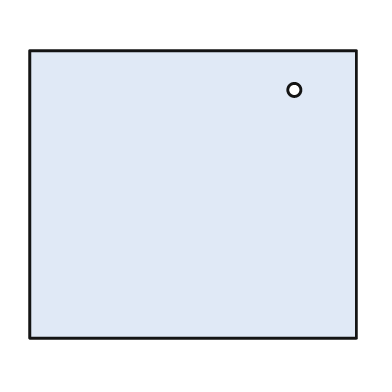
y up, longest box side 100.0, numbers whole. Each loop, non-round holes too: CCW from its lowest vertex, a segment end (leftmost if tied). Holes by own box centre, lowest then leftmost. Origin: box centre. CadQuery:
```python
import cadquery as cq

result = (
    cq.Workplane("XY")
    .moveTo(-50.0, -44.0)
    .lineTo(50.0, -44.0)
    .lineTo(50.0, 44.0)
    .lineTo(-50.0, 44.0)
    .close()
    .moveTo(31.0, 32.0)
    .circle(2.0)
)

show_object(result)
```